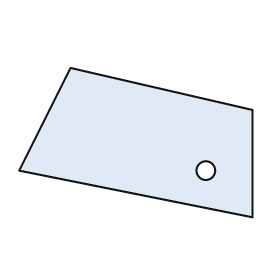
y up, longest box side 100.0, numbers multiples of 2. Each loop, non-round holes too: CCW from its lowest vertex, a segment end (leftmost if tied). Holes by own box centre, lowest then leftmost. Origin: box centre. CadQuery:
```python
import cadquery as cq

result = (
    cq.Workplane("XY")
    .moveTo(50.0, -32.0)
    .lineTo(50.0, 14.0)
    .lineTo(-28.0, 32.0)
    .lineTo(-50.0, -12.0)
    .close()
    .moveTo(30.0, -12.0)
    .circle(4.0)
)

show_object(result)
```